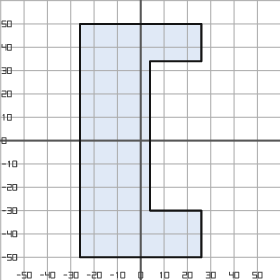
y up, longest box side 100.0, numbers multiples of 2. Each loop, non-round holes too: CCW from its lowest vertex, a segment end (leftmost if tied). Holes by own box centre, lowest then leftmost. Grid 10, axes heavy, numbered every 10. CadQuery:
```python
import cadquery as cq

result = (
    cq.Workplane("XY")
    .moveTo(-26.0, -50.0)
    .lineTo(26.0, -50.0)
    .lineTo(26.0, -30.0)
    .lineTo(4.0, -30.0)
    .lineTo(4.0, 34.0)
    .lineTo(26.0, 34.0)
    .lineTo(26.0, 50.0)
    .lineTo(-26.0, 50.0)
    .close()
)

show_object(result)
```